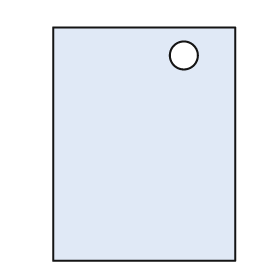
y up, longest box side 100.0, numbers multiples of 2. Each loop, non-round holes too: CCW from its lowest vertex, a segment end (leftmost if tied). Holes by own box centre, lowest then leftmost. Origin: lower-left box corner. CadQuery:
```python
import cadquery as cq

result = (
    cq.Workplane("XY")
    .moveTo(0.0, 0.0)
    .lineTo(78.0, 0.0)
    .lineTo(78.0, 100.0)
    .lineTo(0.0, 100.0)
    .close()
    .moveTo(56.0, 88.0)
    .circle(6.0)
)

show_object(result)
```